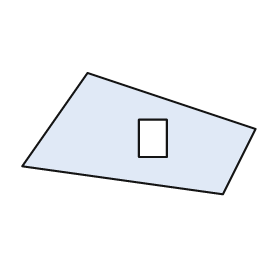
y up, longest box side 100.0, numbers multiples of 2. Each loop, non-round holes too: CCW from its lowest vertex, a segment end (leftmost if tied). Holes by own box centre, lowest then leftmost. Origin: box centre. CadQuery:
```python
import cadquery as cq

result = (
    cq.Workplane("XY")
    .moveTo(36.0, -26.0)
    .lineTo(50.0, 2.0)
    .lineTo(-22.0, 26.0)
    .lineTo(-50.0, -14.0)
    .close()
    .moveTo(0.0, -10.0)
    .lineTo(12.0, -10.0)
    .lineTo(12.0, 6.0)
    .lineTo(0.0, 6.0)
    .close()
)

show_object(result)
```